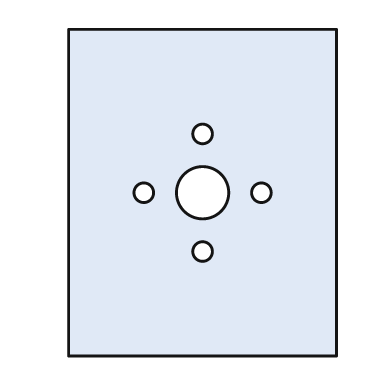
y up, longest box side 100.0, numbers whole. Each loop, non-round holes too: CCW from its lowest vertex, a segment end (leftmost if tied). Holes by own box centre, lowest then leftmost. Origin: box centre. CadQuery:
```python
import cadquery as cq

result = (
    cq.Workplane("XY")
    .moveTo(-41.0, -50.0)
    .lineTo(41.0, -50.0)
    .lineTo(41.0, 50.0)
    .lineTo(-41.0, 50.0)
    .close()
    .moveTo(0.0, -18.0)
    .circle(3.0)
    .moveTo(-18.0, 0.0)
    .circle(3.0)
    .moveTo(0.0, 0.0)
    .circle(8.0)
    .moveTo(18.0, 0.0)
    .circle(3.0)
    .moveTo(0.0, 18.0)
    .circle(3.0)
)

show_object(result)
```